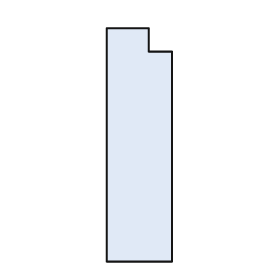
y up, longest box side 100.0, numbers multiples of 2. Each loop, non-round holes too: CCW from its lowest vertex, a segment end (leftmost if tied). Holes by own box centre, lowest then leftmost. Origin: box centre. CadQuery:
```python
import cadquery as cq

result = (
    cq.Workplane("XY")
    .moveTo(-14.0, -50.0)
    .lineTo(14.0, -50.0)
    .lineTo(14.0, 40.0)
    .lineTo(4.0, 40.0)
    .lineTo(4.0, 50.0)
    .lineTo(-14.0, 50.0)
    .close()
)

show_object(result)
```